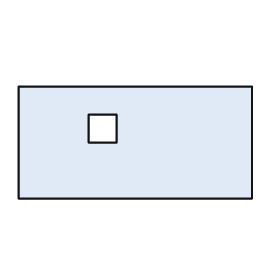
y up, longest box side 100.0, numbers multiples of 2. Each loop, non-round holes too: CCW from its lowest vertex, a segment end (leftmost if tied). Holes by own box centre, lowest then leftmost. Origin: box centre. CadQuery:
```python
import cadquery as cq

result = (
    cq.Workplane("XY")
    .moveTo(-50.0, -24.0)
    .lineTo(50.0, -24.0)
    .lineTo(50.0, 24.0)
    .lineTo(-50.0, 24.0)
    .close()
    .moveTo(-20.0, 0.0)
    .lineTo(-8.0, 0.0)
    .lineTo(-8.0, 12.0)
    .lineTo(-20.0, 12.0)
    .close()
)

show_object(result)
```